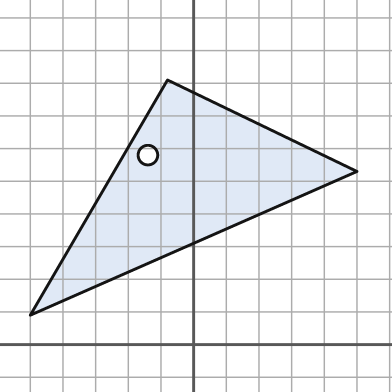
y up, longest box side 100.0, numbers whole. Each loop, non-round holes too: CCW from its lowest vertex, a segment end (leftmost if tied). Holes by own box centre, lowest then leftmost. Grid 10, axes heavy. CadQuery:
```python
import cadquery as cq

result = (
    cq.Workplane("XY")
    .moveTo(-50.0, 9.0)
    .lineTo(50.0, 53.0)
    .lineTo(-8.0, 81.0)
    .close()
    .moveTo(-14.0, 58.0)
    .circle(3.0)
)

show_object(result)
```